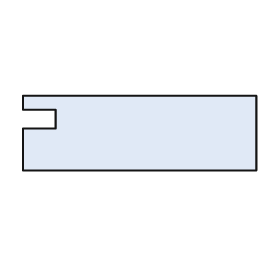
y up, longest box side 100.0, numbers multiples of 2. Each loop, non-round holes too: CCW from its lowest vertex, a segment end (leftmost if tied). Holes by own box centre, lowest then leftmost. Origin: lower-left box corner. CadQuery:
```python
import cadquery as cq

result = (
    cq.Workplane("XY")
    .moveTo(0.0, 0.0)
    .lineTo(100.0, 0.0)
    .lineTo(100.0, 32.0)
    .lineTo(0.0, 32.0)
    .lineTo(0.0, 26.0)
    .lineTo(14.0, 26.0)
    .lineTo(14.0, 18.0)
    .lineTo(0.0, 18.0)
    .close()
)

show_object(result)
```